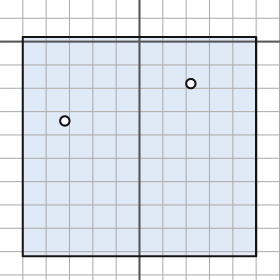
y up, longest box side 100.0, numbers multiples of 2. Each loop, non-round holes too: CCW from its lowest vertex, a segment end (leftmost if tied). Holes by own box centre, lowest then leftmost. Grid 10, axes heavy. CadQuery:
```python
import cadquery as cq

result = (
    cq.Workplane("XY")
    .moveTo(-50.0, -92.0)
    .lineTo(50.0, -92.0)
    .lineTo(50.0, 2.0)
    .lineTo(-50.0, 2.0)
    .close()
    .moveTo(-32.0, -34.0)
    .circle(2.0)
    .moveTo(22.0, -18.0)
    .circle(2.0)
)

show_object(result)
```